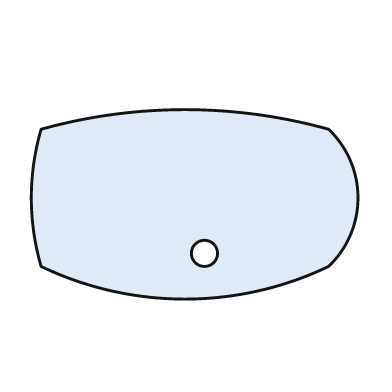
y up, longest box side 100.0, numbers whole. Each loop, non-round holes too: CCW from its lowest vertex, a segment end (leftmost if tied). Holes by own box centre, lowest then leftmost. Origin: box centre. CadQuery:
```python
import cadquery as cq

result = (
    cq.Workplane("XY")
    .moveTo(-47.0, -19.0)
    .threePointArc((-3.0, -29.0), (41.0, -19.0))
    .threePointArc((50.0, 2.0), (41.0, 23.0))
    .threePointArc((-3.0, 29.0), (-47.0, 23.0))
    .threePointArc((-50.0, 2.0), (-47.0, -19.0))
    .close()
    .moveTo(3.0, -15.0)
    .circle(4.0)
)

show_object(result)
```